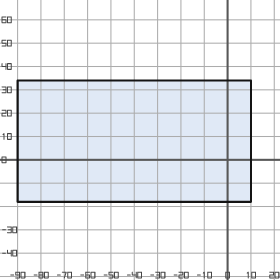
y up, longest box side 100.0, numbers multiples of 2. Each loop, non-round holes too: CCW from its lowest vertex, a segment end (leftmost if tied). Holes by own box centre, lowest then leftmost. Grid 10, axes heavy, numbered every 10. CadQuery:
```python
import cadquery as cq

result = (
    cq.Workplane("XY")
    .moveTo(-90.0, -18.0)
    .lineTo(10.0, -18.0)
    .lineTo(10.0, 34.0)
    .lineTo(-90.0, 34.0)
    .close()
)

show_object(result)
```